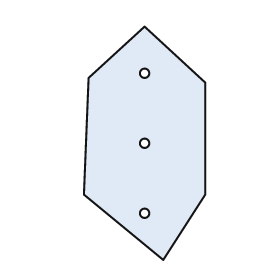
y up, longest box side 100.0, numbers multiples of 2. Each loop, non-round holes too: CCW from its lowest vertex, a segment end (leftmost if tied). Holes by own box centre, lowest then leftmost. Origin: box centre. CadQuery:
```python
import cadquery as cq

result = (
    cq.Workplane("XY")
    .moveTo(8.0, -50.0)
    .lineTo(26.0, -22.0)
    .lineTo(26.0, 26.0)
    .lineTo(0.0, 50.0)
    .lineTo(-24.0, 28.0)
    .lineTo(-26.0, -22.0)
    .close()
    .moveTo(0.0, -30.0)
    .circle(2.0)
    .moveTo(0.0, 0.0)
    .circle(2.0)
    .moveTo(0.0, 30.0)
    .circle(2.0)
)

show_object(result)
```